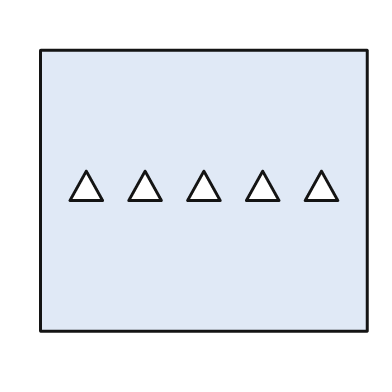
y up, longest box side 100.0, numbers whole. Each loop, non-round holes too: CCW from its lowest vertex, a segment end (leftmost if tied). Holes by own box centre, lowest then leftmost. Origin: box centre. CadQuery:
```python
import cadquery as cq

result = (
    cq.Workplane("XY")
    .moveTo(-50.0, -43.0)
    .lineTo(50.0, -43.0)
    .lineTo(50.0, 43.0)
    .lineTo(-50.0, 43.0)
    .close()
    .moveTo(-41.0, -3.0)
    .lineTo(-31.0, -3.0)
    .lineTo(-36.0, 6.0)
    .close()
    .moveTo(-23.0, -3.0)
    .lineTo(-13.0, -3.0)
    .lineTo(-18.0, 6.0)
    .close()
    .moveTo(-5.0, -3.0)
    .lineTo(5.0, -3.0)
    .lineTo(0.0, 6.0)
    .close()
    .moveTo(13.0, -3.0)
    .lineTo(23.0, -3.0)
    .lineTo(18.0, 6.0)
    .close()
    .moveTo(31.0, -3.0)
    .lineTo(41.0, -3.0)
    .lineTo(36.0, 6.0)
    .close()
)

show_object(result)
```